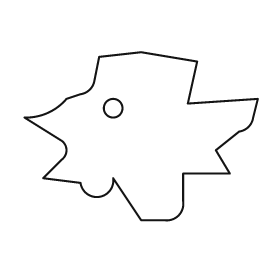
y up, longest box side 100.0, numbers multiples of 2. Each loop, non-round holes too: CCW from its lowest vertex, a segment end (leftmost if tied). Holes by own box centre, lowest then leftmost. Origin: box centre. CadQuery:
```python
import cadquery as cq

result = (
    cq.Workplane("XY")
    .moveTo(0.0, -36.0)
    .lineTo(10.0, -36.0)
    .threePointArc((16.0, -34.0), (18.0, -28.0))
    .lineTo(18.0, -16.0)
    .lineTo(38.0, -16.0)
    .lineTo(32.0, -6.0)
    .lineTo(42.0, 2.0)
    .threePointArc((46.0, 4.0), (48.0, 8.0))
    .lineTo(50.0, 16.0)
    .lineTo(20.0, 14.0)
    .lineTo(24.0, 32.0)
    .lineTo(0.0, 36.0)
    .lineTo(-18.0, 34.0)
    .lineTo(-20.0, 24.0)
    .threePointArc((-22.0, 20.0), (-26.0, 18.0))
    .lineTo(-32.0, 16.0)
    .threePointArc((-40.0, 10.0), (-50.0, 8.0))
    .lineTo(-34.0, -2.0)
    .threePointArc((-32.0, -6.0), (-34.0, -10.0))
    .lineTo(-42.0, -18.0)
    .lineTo(-26.0, -20.0)
    .threePointArc((-18.0, -26.0), (-12.0, -18.0))
    .close()
    .moveTo(-12.0, 12.0)
    .circle(4.0)
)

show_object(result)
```